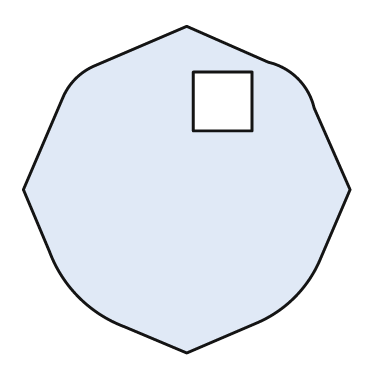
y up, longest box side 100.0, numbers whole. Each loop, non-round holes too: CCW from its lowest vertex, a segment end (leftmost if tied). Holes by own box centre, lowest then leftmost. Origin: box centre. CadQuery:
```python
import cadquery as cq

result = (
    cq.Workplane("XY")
    .moveTo(0.0, -50.0)
    .lineTo(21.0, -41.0)
    .threePointArc((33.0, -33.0), (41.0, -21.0))
    .lineTo(50.0, 0.0)
    .lineTo(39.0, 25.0)
    .threePointArc((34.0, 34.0), (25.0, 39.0))
    .lineTo(0.0, 50.0)
    .lineTo(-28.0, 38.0)
    .threePointArc((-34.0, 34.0), (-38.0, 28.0))
    .lineTo(-50.0, 0.0)
    .lineTo(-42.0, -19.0)
    .threePointArc((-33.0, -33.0), (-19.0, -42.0))
    .close()
    .moveTo(2.0, 18.0)
    .lineTo(20.0, 18.0)
    .lineTo(20.0, 36.0)
    .lineTo(2.0, 36.0)
    .close()
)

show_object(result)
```